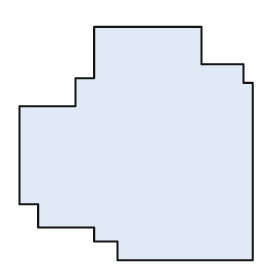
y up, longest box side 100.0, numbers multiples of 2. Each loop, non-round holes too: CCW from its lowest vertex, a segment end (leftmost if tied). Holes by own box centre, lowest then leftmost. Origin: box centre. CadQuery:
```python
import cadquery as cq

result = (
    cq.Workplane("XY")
    .moveTo(-8.0, -50.0)
    .lineTo(50.0, -50.0)
    .lineTo(50.0, 26.0)
    .lineTo(46.0, 26.0)
    .lineTo(46.0, 34.0)
    .lineTo(28.0, 34.0)
    .lineTo(28.0, 50.0)
    .lineTo(-18.0, 50.0)
    .lineTo(-18.0, 28.0)
    .lineTo(-26.0, 28.0)
    .lineTo(-26.0, 16.0)
    .lineTo(-50.0, 16.0)
    .lineTo(-50.0, -26.0)
    .lineTo(-42.0, -26.0)
    .lineTo(-42.0, -36.0)
    .lineTo(-18.0, -36.0)
    .lineTo(-18.0, -42.0)
    .lineTo(-8.0, -42.0)
    .close()
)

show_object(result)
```